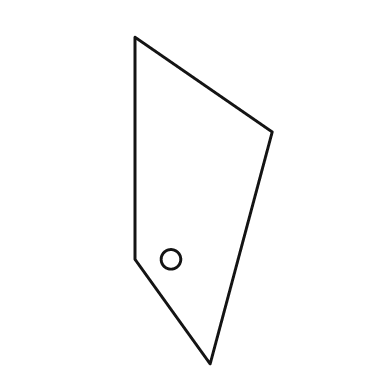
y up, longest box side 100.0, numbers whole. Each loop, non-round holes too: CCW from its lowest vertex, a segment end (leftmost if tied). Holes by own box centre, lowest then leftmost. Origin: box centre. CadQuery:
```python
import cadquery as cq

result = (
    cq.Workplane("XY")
    .moveTo(2.0, -50.0)
    .lineTo(21.0, 21.0)
    .lineTo(-21.0, 50.0)
    .lineTo(-21.0, -18.0)
    .close()
    .moveTo(-10.0, -18.0)
    .circle(3.0)
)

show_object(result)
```